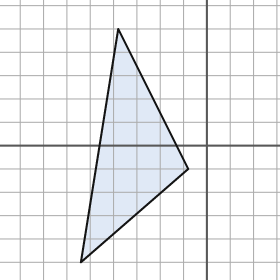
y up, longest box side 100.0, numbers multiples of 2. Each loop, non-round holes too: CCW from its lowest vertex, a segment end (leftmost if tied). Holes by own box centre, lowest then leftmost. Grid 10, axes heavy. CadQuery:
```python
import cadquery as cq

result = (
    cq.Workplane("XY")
    .moveTo(-54.0, -50.0)
    .lineTo(-8.0, -10.0)
    .lineTo(-38.0, 50.0)
    .close()
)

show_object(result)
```